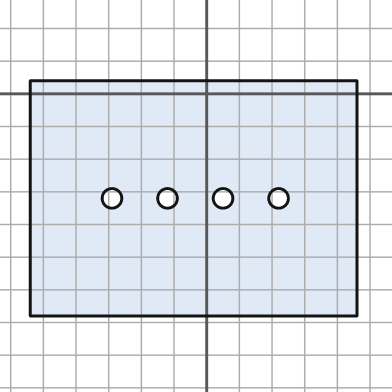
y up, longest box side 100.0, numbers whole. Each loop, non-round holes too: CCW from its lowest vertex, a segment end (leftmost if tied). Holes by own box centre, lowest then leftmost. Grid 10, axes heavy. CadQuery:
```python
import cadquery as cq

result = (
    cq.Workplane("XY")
    .moveTo(-54.0, -68.0)
    .lineTo(46.0, -68.0)
    .lineTo(46.0, 4.0)
    .lineTo(-54.0, 4.0)
    .close()
    .moveTo(-29.0, -32.0)
    .circle(3.0)
    .moveTo(-12.0, -32.0)
    .circle(3.0)
    .moveTo(5.0, -32.0)
    .circle(3.0)
    .moveTo(22.0, -32.0)
    .circle(3.0)
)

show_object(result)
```